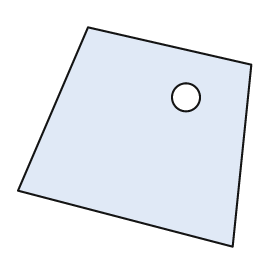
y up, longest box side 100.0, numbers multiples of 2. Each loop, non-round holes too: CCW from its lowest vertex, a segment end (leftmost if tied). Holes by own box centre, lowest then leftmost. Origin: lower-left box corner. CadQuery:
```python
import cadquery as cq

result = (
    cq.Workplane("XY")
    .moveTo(92.0, 0.0)
    .lineTo(100.0, 78.0)
    .lineTo(30.0, 94.0)
    .lineTo(0.0, 24.0)
    .close()
    .moveTo(72.0, 64.0)
    .circle(6.0)
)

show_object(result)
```